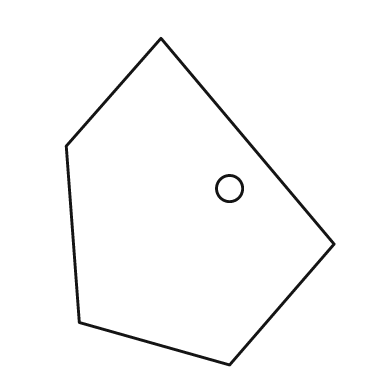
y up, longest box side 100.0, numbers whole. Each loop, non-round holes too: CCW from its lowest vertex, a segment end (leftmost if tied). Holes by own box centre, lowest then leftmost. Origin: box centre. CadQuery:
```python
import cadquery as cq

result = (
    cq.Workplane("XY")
    .moveTo(9.0, -50.0)
    .lineTo(41.0, -13.0)
    .lineTo(-12.0, 50.0)
    .lineTo(-41.0, 17.0)
    .lineTo(-37.0, -37.0)
    .close()
    .moveTo(9.0, 4.0)
    .circle(4.0)
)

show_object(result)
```